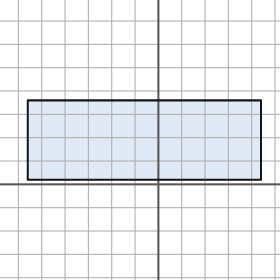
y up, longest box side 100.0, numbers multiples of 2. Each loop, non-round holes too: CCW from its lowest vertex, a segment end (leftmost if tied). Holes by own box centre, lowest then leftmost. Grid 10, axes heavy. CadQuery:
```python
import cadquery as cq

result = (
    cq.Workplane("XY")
    .moveTo(-56.0, 2.0)
    .lineTo(44.0, 2.0)
    .lineTo(44.0, 36.0)
    .lineTo(-56.0, 36.0)
    .close()
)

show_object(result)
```